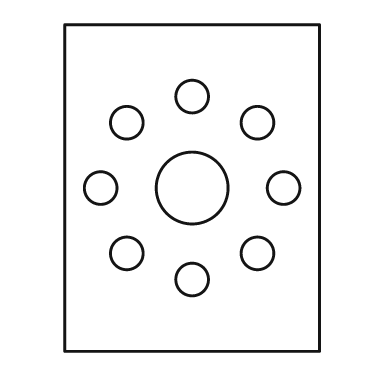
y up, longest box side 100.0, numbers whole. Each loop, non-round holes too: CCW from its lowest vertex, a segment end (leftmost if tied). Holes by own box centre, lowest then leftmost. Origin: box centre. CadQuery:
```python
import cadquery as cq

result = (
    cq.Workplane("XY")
    .moveTo(-39.0, -50.0)
    .lineTo(39.0, -50.0)
    .lineTo(39.0, 50.0)
    .lineTo(-39.0, 50.0)
    .close()
    .moveTo(0.0, -28.0)
    .circle(5.0)
    .moveTo(-20.0, -20.0)
    .circle(5.0)
    .moveTo(20.0, -20.0)
    .circle(5.0)
    .moveTo(-28.0, 0.0)
    .circle(5.0)
    .moveTo(0.0, 0.0)
    .circle(11.0)
    .moveTo(28.0, 0.0)
    .circle(5.0)
    .moveTo(-20.0, 20.0)
    .circle(5.0)
    .moveTo(20.0, 20.0)
    .circle(5.0)
    .moveTo(0.0, 28.0)
    .circle(5.0)
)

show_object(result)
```